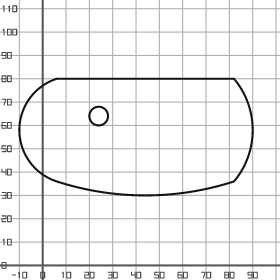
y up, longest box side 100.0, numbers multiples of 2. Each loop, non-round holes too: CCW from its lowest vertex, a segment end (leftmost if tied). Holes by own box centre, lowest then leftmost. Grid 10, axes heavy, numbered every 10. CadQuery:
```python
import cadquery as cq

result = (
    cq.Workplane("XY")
    .moveTo(6.0, 36.0)
    .threePointArc((44.0, 30.0), (82.0, 36.0))
    .threePointArc((90.0, 58.0), (82.0, 80.0))
    .lineTo(6.0, 80.0)
    .threePointArc((-10.0, 58.0), (6.0, 36.0))
    .close()
    .moveTo(24.0, 64.0)
    .circle(4.0)
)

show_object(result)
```